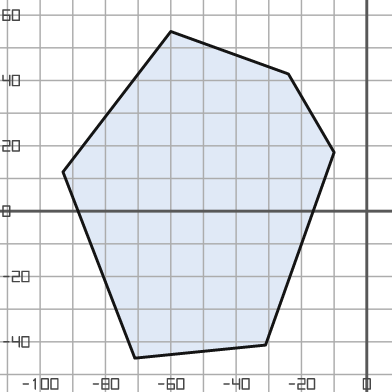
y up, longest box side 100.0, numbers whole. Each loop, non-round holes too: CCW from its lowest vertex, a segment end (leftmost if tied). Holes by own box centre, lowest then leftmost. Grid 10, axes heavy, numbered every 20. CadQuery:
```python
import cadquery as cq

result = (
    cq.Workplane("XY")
    .moveTo(-71.0, -45.0)
    .lineTo(-31.0, -41.0)
    .lineTo(-10.0, 18.0)
    .lineTo(-24.0, 42.0)
    .lineTo(-60.0, 55.0)
    .lineTo(-93.0, 12.0)
    .close()
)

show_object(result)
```